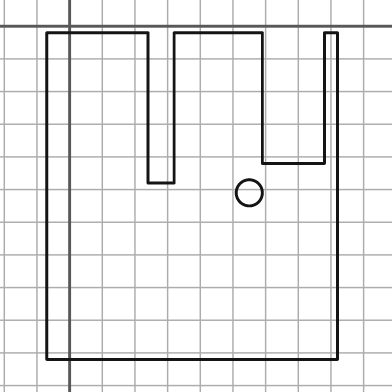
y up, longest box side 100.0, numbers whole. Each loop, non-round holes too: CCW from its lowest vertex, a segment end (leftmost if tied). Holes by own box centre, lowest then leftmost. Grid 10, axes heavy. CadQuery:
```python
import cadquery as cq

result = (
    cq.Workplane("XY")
    .moveTo(-7.0, -102.0)
    .lineTo(82.0, -102.0)
    .lineTo(82.0, -2.0)
    .lineTo(78.0, -2.0)
    .lineTo(78.0, -42.0)
    .lineTo(59.0, -42.0)
    .lineTo(59.0, -2.0)
    .lineTo(32.0, -2.0)
    .lineTo(32.0, -48.0)
    .lineTo(24.0, -48.0)
    .lineTo(24.0, -2.0)
    .lineTo(-7.0, -2.0)
    .close()
    .moveTo(55.0, -51.0)
    .circle(4.0)
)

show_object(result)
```